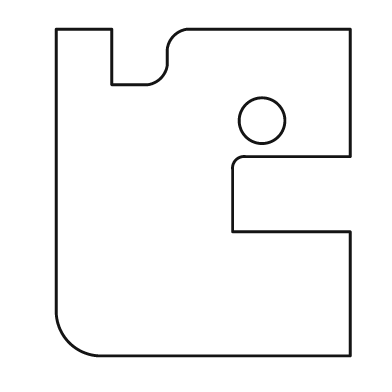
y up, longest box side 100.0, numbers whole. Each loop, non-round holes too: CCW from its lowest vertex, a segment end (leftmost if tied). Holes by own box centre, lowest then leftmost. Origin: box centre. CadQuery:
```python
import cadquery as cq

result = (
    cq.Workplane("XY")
    .moveTo(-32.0, -50.0)
    .lineTo(45.0, -50.0)
    .lineTo(45.0, -12.0)
    .lineTo(9.0, -12.0)
    .lineTo(9.0, 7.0)
    .threePointArc((10.0, 10.0), (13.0, 11.0))
    .lineTo(45.0, 11.0)
    .lineTo(45.0, 50.0)
    .lineTo(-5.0, 50.0)
    .threePointArc((-9.0, 48.0), (-11.0, 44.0))
    .lineTo(-11.0, 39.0)
    .threePointArc((-13.0, 35.0), (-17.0, 33.0))
    .lineTo(-28.0, 33.0)
    .lineTo(-28.0, 50.0)
    .lineTo(-45.0, 50.0)
    .lineTo(-45.0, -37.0)
    .threePointArc((-41.0, -46.0), (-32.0, -50.0))
    .close()
    .moveTo(18.0, 22.0)
    .circle(7.0)
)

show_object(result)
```